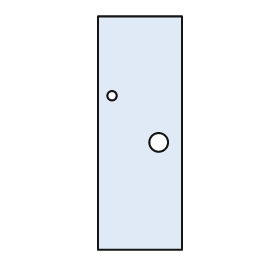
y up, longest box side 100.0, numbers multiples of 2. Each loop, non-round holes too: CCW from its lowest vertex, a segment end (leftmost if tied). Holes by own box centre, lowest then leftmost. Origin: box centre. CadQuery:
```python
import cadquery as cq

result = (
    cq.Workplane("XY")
    .moveTo(-18.0, -50.0)
    .lineTo(18.0, -50.0)
    .lineTo(18.0, 50.0)
    .lineTo(-18.0, 50.0)
    .close()
    .moveTo(8.0, -4.0)
    .circle(4.0)
    .moveTo(-12.0, 16.0)
    .circle(2.0)
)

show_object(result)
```